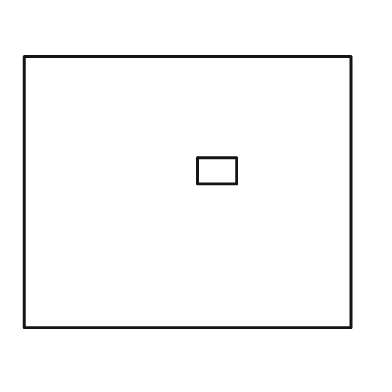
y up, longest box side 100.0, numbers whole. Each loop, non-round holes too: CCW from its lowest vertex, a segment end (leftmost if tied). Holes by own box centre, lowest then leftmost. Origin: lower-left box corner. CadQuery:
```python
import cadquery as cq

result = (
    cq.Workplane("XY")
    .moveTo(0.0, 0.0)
    .lineTo(100.0, 0.0)
    .lineTo(100.0, 83.0)
    .lineTo(0.0, 83.0)
    .close()
    .moveTo(53.0, 44.0)
    .lineTo(65.0, 44.0)
    .lineTo(65.0, 52.0)
    .lineTo(53.0, 52.0)
    .close()
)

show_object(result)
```